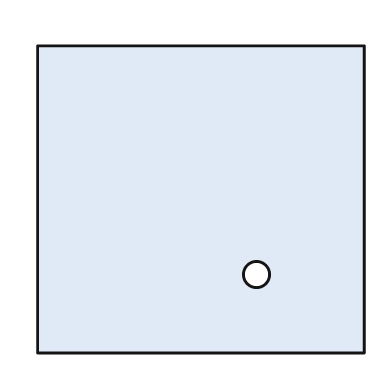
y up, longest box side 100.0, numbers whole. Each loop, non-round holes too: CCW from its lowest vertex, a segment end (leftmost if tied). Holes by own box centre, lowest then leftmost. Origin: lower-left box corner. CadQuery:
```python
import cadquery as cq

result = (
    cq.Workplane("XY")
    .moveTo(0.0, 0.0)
    .lineTo(100.0, 0.0)
    .lineTo(100.0, 94.0)
    .lineTo(0.0, 94.0)
    .close()
    .moveTo(67.0, 24.0)
    .circle(4.0)
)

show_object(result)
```